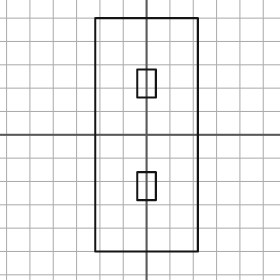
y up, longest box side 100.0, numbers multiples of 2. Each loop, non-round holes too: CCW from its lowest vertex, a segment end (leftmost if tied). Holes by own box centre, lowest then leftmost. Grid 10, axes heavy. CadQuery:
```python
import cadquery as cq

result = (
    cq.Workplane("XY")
    .moveTo(-22.0, -50.0)
    .lineTo(22.0, -50.0)
    .lineTo(22.0, 50.0)
    .lineTo(-22.0, 50.0)
    .close()
    .moveTo(-4.0, -28.0)
    .lineTo(4.0, -28.0)
    .lineTo(4.0, -16.0)
    .lineTo(-4.0, -16.0)
    .close()
    .moveTo(-4.0, 16.0)
    .lineTo(4.0, 16.0)
    .lineTo(4.0, 28.0)
    .lineTo(-4.0, 28.0)
    .close()
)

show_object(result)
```